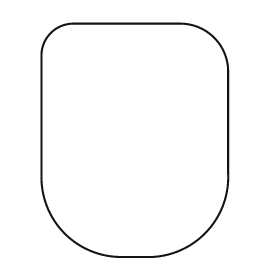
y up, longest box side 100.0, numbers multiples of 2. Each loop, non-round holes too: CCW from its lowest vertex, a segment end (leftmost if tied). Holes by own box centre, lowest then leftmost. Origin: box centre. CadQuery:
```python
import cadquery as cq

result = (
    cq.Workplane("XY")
    .moveTo(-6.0, -50.0)
    .lineTo(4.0, -50.0)
    .threePointArc((30.0, -40.0), (40.0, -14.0))
    .lineTo(40.0, 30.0)
    .threePointArc((34.0, 44.0), (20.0, 50.0))
    .lineTo(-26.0, 50.0)
    .threePointArc((-36.0, 46.0), (-40.0, 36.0))
    .lineTo(-40.0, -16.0)
    .threePointArc((-30.0, -40.0), (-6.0, -50.0))
    .close()
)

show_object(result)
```